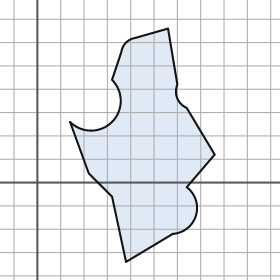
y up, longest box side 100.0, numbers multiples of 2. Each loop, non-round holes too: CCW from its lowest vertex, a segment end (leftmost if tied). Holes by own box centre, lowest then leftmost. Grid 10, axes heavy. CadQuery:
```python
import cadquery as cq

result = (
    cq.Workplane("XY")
    .moveTo(38.0, -34.0)
    .lineTo(58.0, -22.0)
    .threePointArc((68.0, -14.0), (64.0, -2.0))
    .lineTo(76.0, 12.0)
    .lineTo(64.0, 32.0)
    .threePointArc((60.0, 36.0), (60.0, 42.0))
    .lineTo(56.0, 66.0)
    .lineTo(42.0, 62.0)
    .threePointArc((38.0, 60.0), (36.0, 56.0))
    .lineTo(32.0, 44.0)
    .threePointArc((32.0, 26.0), (14.0, 26.0))
    .lineTo(22.0, 4.0)
    .lineTo(32.0, -6.0)
    .close()
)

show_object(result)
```